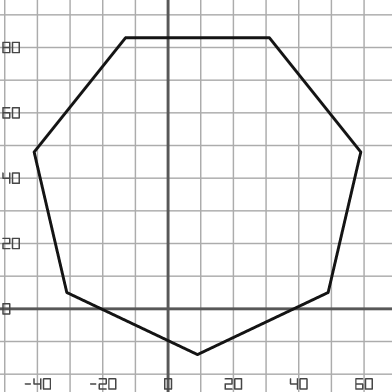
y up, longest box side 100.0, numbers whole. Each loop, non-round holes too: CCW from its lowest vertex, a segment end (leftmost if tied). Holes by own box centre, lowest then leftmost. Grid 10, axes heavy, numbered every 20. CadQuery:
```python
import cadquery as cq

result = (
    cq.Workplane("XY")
    .moveTo(9.0, -14.0)
    .lineTo(49.0, 5.0)
    .lineTo(59.0, 48.0)
    .lineTo(31.0, 83.0)
    .lineTo(-13.0, 83.0)
    .lineTo(-41.0, 48.0)
    .lineTo(-31.0, 5.0)
    .close()
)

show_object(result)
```